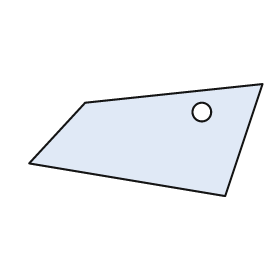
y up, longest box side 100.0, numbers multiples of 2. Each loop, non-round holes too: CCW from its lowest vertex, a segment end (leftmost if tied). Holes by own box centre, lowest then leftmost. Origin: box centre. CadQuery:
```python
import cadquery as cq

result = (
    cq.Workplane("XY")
    .moveTo(34.0, -24.0)
    .lineTo(50.0, 24.0)
    .lineTo(-26.0, 16.0)
    .lineTo(-50.0, -10.0)
    .close()
    .moveTo(24.0, 12.0)
    .circle(4.0)
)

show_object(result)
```